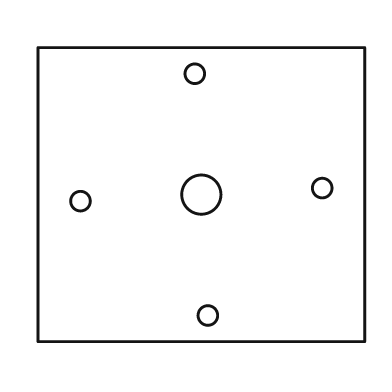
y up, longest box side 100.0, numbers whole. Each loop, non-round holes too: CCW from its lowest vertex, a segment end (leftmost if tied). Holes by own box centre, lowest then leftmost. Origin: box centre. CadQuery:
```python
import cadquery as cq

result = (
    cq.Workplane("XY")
    .moveTo(-50.0, -45.0)
    .lineTo(50.0, -45.0)
    .lineTo(50.0, 45.0)
    .lineTo(-50.0, 45.0)
    .close()
    .moveTo(2.0, -37.0)
    .circle(3.0)
    .moveTo(-37.0, -2.0)
    .circle(3.0)
    .moveTo(0.0, 0.0)
    .circle(6.0)
    .moveTo(37.0, 2.0)
    .circle(3.0)
    .moveTo(-2.0, 37.0)
    .circle(3.0)
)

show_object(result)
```